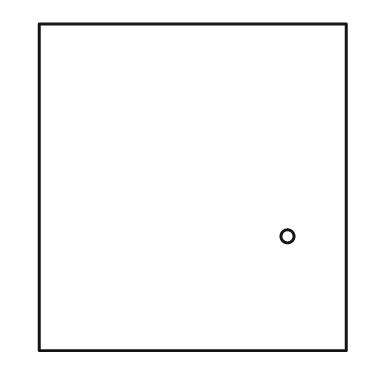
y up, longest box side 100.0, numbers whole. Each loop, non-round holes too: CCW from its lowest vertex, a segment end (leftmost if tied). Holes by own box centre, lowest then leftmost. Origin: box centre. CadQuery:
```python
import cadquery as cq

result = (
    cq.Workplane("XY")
    .moveTo(-47.0, -50.0)
    .lineTo(47.0, -50.0)
    .lineTo(47.0, 50.0)
    .lineTo(-47.0, 50.0)
    .close()
    .moveTo(29.0, -15.0)
    .circle(2.0)
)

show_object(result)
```